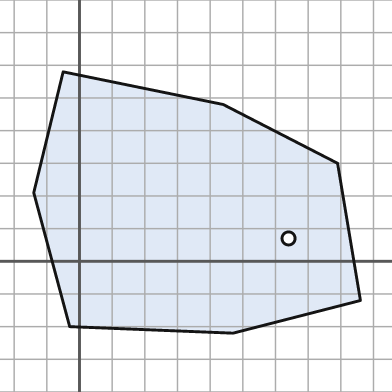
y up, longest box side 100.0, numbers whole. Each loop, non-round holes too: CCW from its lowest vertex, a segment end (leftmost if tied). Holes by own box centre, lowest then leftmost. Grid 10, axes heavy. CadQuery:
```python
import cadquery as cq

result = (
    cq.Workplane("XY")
    .moveTo(47.0, -22.0)
    .lineTo(86.0, -12.0)
    .lineTo(79.0, 30.0)
    .lineTo(44.0, 48.0)
    .lineTo(-5.0, 58.0)
    .lineTo(-14.0, 21.0)
    .lineTo(-3.0, -20.0)
    .close()
    .moveTo(64.0, 7.0)
    .circle(2.0)
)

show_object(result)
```